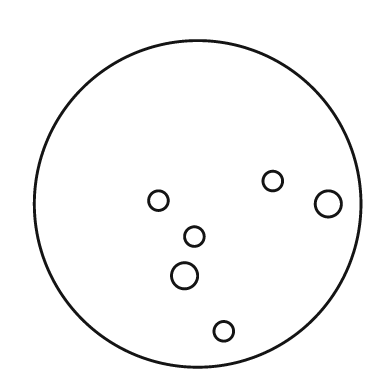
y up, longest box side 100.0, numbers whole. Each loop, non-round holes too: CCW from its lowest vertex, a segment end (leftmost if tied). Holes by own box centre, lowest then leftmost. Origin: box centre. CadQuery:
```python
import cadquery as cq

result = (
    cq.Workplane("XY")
    .moveTo(0.0, 0.0)
    .circle(50.0)
    .moveTo(8.0, -39.0)
    .circle(3.0)
    .moveTo(-4.0, -22.0)
    .circle(4.0)
    .moveTo(-1.0, -10.0)
    .circle(3.0)
    .moveTo(40.0, 0.0)
    .circle(4.0)
    .moveTo(-12.0, 1.0)
    .circle(3.0)
    .moveTo(23.0, 7.0)
    .circle(3.0)
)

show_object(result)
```